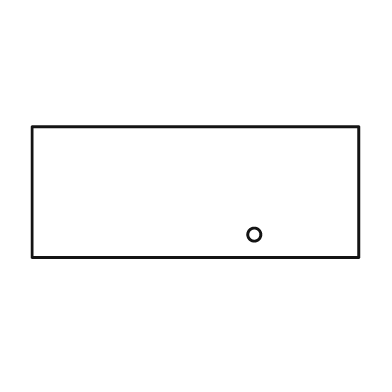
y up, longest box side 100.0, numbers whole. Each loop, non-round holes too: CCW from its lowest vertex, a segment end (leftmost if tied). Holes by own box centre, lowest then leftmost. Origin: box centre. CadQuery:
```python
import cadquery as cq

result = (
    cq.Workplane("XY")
    .moveTo(-50.0, -20.0)
    .lineTo(50.0, -20.0)
    .lineTo(50.0, 20.0)
    .lineTo(-50.0, 20.0)
    .close()
    .moveTo(18.0, -13.0)
    .circle(2.0)
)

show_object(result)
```